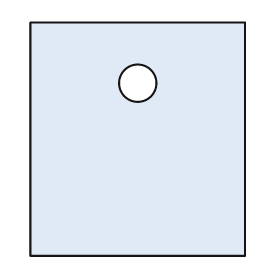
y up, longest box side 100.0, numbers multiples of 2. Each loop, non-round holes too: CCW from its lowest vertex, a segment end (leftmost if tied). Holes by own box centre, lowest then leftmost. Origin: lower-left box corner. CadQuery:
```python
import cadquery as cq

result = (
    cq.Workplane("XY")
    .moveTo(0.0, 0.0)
    .lineTo(92.0, 0.0)
    .lineTo(92.0, 100.0)
    .lineTo(0.0, 100.0)
    .close()
    .moveTo(46.0, 74.0)
    .circle(8.0)
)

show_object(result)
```